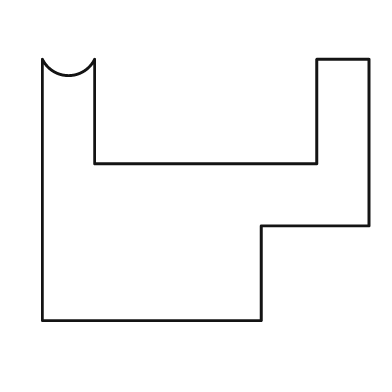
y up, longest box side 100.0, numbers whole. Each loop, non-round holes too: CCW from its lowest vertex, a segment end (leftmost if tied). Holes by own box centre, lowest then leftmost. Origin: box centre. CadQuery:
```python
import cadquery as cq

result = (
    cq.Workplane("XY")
    .moveTo(-50.0, -40.0)
    .lineTo(17.0, -40.0)
    .lineTo(17.0, -11.0)
    .lineTo(50.0, -11.0)
    .lineTo(50.0, 40.0)
    .lineTo(34.0, 40.0)
    .lineTo(34.0, 8.0)
    .lineTo(-34.0, 8.0)
    .lineTo(-34.0, 40.0)
    .threePointArc((-42.0, 35.0), (-50.0, 40.0))
    .close()
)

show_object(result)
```